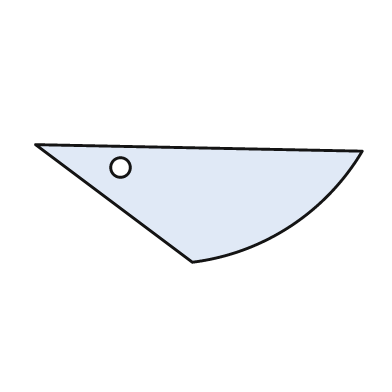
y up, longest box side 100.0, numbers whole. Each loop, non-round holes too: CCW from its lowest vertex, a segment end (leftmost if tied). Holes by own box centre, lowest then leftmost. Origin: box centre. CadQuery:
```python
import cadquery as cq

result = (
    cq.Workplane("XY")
    .moveTo(-2.0, -18.0)
    .threePointArc((28.0, -7.0), (50.0, 16.0))
    .lineTo(-50.0, 18.0)
    .close()
    .moveTo(-24.0, 11.0)
    .circle(3.0)
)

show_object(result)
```